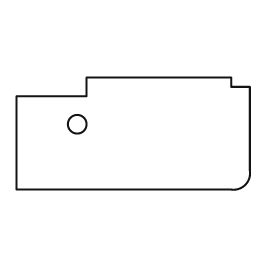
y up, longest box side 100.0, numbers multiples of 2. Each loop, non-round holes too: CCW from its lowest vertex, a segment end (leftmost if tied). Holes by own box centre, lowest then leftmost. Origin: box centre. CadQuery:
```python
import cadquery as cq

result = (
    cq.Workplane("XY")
    .moveTo(-50.0, -24.0)
    .lineTo(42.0, -24.0)
    .threePointArc((48.0, -22.0), (50.0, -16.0))
    .lineTo(50.0, 20.0)
    .lineTo(42.0, 20.0)
    .lineTo(42.0, 24.0)
    .lineTo(-20.0, 24.0)
    .lineTo(-20.0, 16.0)
    .lineTo(-50.0, 16.0)
    .close()
    .moveTo(-24.0, 4.0)
    .circle(4.0)
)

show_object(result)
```